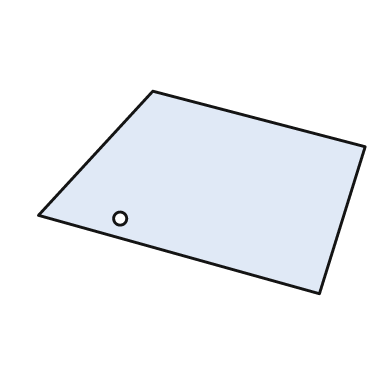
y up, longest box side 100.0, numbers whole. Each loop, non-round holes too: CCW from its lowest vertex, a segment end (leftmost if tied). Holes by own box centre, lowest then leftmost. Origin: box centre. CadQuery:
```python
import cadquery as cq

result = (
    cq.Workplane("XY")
    .moveTo(36.0, -31.0)
    .lineTo(50.0, 14.0)
    .lineTo(-15.0, 31.0)
    .lineTo(-50.0, -7.0)
    .close()
    .moveTo(-25.0, -8.0)
    .circle(2.0)
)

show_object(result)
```